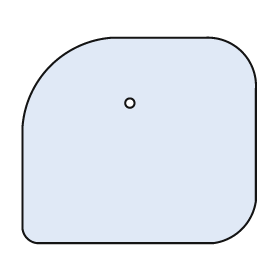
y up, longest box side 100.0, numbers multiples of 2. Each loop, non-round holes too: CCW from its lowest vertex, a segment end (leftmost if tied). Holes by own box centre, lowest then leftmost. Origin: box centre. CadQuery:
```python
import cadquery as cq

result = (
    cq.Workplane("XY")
    .moveTo(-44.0, -44.0)
    .lineTo(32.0, -44.0)
    .threePointArc((44.0, -38.0), (50.0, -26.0))
    .lineTo(50.0, 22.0)
    .threePointArc((44.0, 38.0), (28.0, 44.0))
    .lineTo(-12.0, 44.0)
    .threePointArc((-38.0, 32.0), (-50.0, 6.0))
    .lineTo(-50.0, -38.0)
    .threePointArc((-48.0, -42.0), (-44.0, -44.0))
    .close()
    .moveTo(-4.0, 16.0)
    .circle(2.0)
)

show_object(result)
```